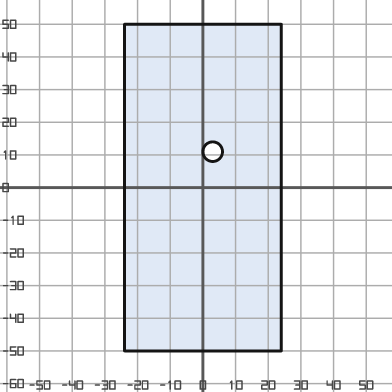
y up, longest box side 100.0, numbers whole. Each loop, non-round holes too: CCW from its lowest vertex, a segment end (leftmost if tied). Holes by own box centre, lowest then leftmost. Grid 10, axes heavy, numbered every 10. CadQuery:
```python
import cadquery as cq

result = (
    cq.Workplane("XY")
    .moveTo(-24.0, -50.0)
    .lineTo(24.0, -50.0)
    .lineTo(24.0, 50.0)
    .lineTo(-24.0, 50.0)
    .close()
    .moveTo(3.0, 11.0)
    .circle(3.0)
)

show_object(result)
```